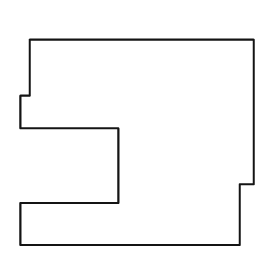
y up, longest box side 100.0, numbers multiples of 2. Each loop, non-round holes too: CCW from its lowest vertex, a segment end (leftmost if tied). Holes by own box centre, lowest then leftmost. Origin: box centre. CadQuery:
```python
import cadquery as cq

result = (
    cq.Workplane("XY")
    .moveTo(-50.0, -44.0)
    .lineTo(44.0, -44.0)
    .lineTo(44.0, -18.0)
    .lineTo(50.0, -18.0)
    .lineTo(50.0, 44.0)
    .lineTo(-46.0, 44.0)
    .lineTo(-46.0, 20.0)
    .lineTo(-50.0, 20.0)
    .lineTo(-50.0, 6.0)
    .lineTo(-8.0, 6.0)
    .lineTo(-8.0, -26.0)
    .lineTo(-50.0, -26.0)
    .close()
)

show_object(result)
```